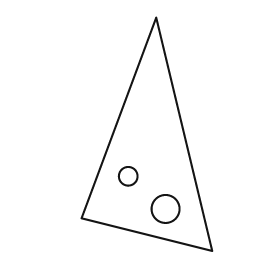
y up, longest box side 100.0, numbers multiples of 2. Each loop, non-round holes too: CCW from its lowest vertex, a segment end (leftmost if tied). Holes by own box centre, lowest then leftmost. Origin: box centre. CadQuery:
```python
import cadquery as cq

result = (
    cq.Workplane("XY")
    .moveTo(28.0, -50.0)
    .lineTo(4.0, 50.0)
    .lineTo(-28.0, -36.0)
    .close()
    .moveTo(8.0, -32.0)
    .circle(6.0)
    .moveTo(-8.0, -18.0)
    .circle(4.0)
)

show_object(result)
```